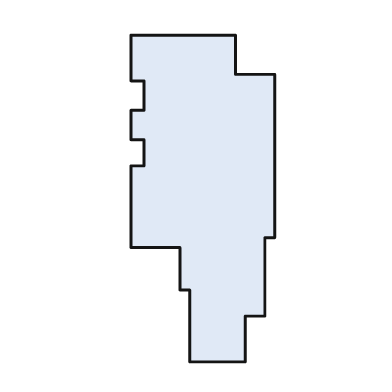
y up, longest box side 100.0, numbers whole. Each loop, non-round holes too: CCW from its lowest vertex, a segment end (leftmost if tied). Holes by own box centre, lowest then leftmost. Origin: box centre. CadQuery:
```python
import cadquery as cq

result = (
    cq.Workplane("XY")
    .moveTo(-4.0, -50.0)
    .lineTo(13.0, -50.0)
    .lineTo(13.0, -36.0)
    .lineTo(19.0, -36.0)
    .lineTo(19.0, -12.0)
    .lineTo(22.0, -12.0)
    .lineTo(22.0, 38.0)
    .lineTo(10.0, 38.0)
    .lineTo(10.0, 50.0)
    .lineTo(-22.0, 50.0)
    .lineTo(-22.0, 36.0)
    .lineTo(-18.0, 36.0)
    .lineTo(-18.0, 27.0)
    .lineTo(-22.0, 27.0)
    .lineTo(-22.0, 18.0)
    .lineTo(-18.0, 18.0)
    .lineTo(-18.0, 10.0)
    .lineTo(-22.0, 10.0)
    .lineTo(-22.0, -15.0)
    .lineTo(-7.0, -15.0)
    .lineTo(-7.0, -28.0)
    .lineTo(-4.0, -28.0)
    .close()
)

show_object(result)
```